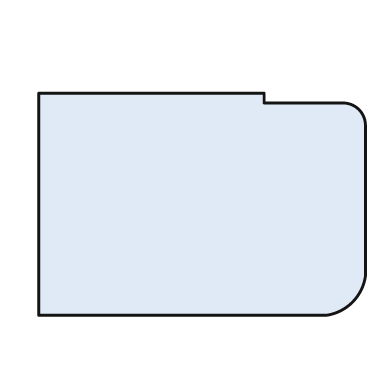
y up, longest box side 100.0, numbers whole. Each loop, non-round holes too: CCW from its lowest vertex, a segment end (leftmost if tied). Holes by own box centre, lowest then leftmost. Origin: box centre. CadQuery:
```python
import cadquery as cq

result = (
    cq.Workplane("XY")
    .moveTo(-50.0, -34.0)
    .lineTo(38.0, -34.0)
    .threePointArc((46.0, -30.0), (50.0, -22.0))
    .lineTo(50.0, 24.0)
    .threePointArc((48.0, 29.0), (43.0, 31.0))
    .lineTo(19.0, 31.0)
    .lineTo(19.0, 34.0)
    .lineTo(-50.0, 34.0)
    .close()
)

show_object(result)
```